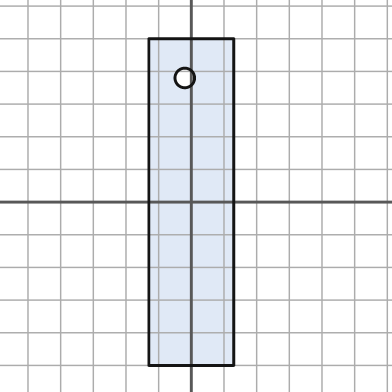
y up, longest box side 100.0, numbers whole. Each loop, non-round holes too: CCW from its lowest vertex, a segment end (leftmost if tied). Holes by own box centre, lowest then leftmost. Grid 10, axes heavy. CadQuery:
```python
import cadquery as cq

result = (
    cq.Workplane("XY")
    .moveTo(-13.0, -50.0)
    .lineTo(13.0, -50.0)
    .lineTo(13.0, 50.0)
    .lineTo(-13.0, 50.0)
    .close()
    .moveTo(-2.0, 38.0)
    .circle(3.0)
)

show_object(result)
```